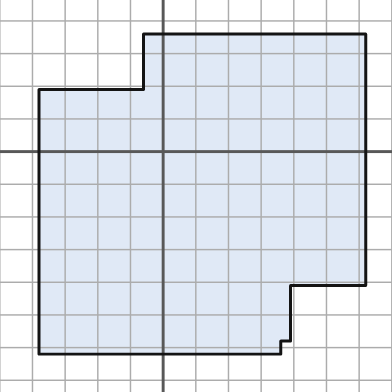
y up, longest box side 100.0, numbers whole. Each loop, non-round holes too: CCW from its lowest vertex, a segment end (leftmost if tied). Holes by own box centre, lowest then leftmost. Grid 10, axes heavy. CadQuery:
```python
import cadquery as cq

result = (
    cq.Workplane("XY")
    .moveTo(-38.0, -62.0)
    .lineTo(36.0, -62.0)
    .lineTo(36.0, -58.0)
    .lineTo(39.0, -58.0)
    .lineTo(39.0, -41.0)
    .lineTo(62.0, -41.0)
    .lineTo(62.0, 36.0)
    .lineTo(-6.0, 36.0)
    .lineTo(-6.0, 19.0)
    .lineTo(-38.0, 19.0)
    .close()
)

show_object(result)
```